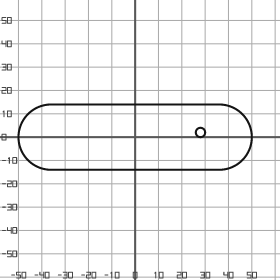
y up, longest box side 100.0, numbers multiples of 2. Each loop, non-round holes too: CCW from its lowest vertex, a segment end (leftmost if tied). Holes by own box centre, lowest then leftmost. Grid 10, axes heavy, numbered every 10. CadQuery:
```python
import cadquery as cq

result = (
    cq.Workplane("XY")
    .moveTo(-36.0, -14.0)
    .lineTo(36.0, -14.0)
    .threePointArc((50.0, 0.0), (36.0, 14.0))
    .lineTo(-36.0, 14.0)
    .threePointArc((-50.0, 0.0), (-36.0, -14.0))
    .close()
    .moveTo(28.0, 2.0)
    .circle(2.0)
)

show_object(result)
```